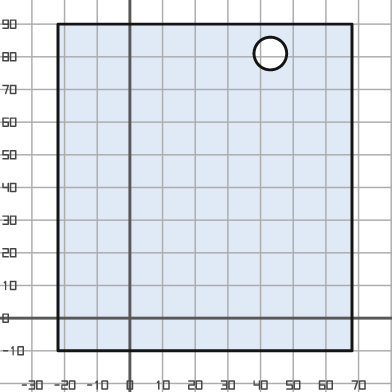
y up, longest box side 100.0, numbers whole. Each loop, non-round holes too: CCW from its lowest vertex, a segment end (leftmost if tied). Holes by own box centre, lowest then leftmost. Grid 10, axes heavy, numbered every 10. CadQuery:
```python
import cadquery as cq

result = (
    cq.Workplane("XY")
    .moveTo(-22.0, -10.0)
    .lineTo(68.0, -10.0)
    .lineTo(68.0, 90.0)
    .lineTo(-22.0, 90.0)
    .close()
    .moveTo(43.0, 81.0)
    .circle(5.0)
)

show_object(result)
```